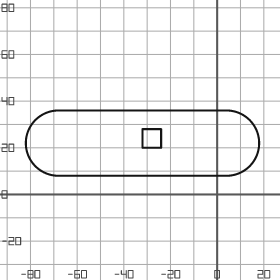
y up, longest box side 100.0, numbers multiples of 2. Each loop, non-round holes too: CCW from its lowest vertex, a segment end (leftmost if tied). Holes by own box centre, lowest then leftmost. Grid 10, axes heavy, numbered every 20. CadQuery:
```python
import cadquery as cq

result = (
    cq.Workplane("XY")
    .moveTo(-68.0, 8.0)
    .lineTo(4.0, 8.0)
    .threePointArc((18.0, 22.0), (4.0, 36.0))
    .lineTo(-68.0, 36.0)
    .threePointArc((-82.0, 22.0), (-68.0, 8.0))
    .close()
    .moveTo(-32.0, 20.0)
    .lineTo(-24.0, 20.0)
    .lineTo(-24.0, 28.0)
    .lineTo(-32.0, 28.0)
    .close()
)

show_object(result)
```